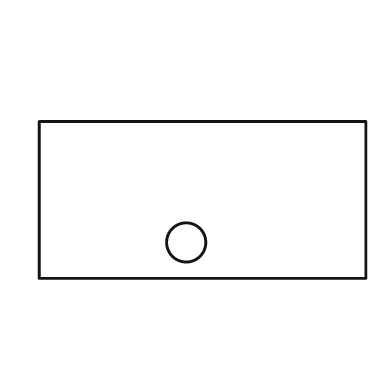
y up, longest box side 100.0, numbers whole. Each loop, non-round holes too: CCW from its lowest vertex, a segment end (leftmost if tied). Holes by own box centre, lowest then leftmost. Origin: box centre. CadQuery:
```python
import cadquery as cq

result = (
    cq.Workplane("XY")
    .moveTo(-50.0, -24.0)
    .lineTo(50.0, -24.0)
    .lineTo(50.0, 24.0)
    .lineTo(-50.0, 24.0)
    .close()
    .moveTo(-5.0, -13.0)
    .circle(6.0)
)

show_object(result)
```